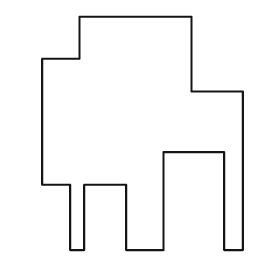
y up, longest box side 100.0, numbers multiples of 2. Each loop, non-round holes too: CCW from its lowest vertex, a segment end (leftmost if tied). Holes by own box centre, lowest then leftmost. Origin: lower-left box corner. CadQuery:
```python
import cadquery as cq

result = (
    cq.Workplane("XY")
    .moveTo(12.0, 0.0)
    .lineTo(18.0, 0.0)
    .lineTo(18.0, 28.0)
    .lineTo(36.0, 28.0)
    .lineTo(36.0, 0.0)
    .lineTo(52.0, 0.0)
    .lineTo(52.0, 42.0)
    .lineTo(78.0, 42.0)
    .lineTo(78.0, 0.0)
    .lineTo(86.0, 0.0)
    .lineTo(86.0, 68.0)
    .lineTo(64.0, 68.0)
    .lineTo(64.0, 100.0)
    .lineTo(16.0, 100.0)
    .lineTo(16.0, 82.0)
    .lineTo(0.0, 82.0)
    .lineTo(0.0, 28.0)
    .lineTo(12.0, 28.0)
    .close()
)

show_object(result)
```